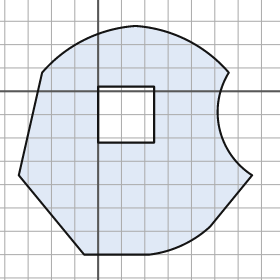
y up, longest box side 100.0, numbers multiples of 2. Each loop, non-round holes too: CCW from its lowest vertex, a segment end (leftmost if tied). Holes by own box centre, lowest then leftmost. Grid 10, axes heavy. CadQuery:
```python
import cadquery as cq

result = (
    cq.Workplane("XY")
    .moveTo(-6.0, -70.0)
    .lineTo(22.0, -70.0)
    .threePointArc((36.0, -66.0), (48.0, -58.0))
    .lineTo(66.0, -36.0)
    .threePointArc((52.0, -16.0), (56.0, 8.0))
    .threePointArc((38.0, 22.0), (16.0, 28.0))
    .threePointArc((-6.0, 22.0), (-24.0, 8.0))
    .lineTo(-34.0, -36.0)
    .close()
    .moveTo(0.0, -22.0)
    .lineTo(24.0, -22.0)
    .lineTo(24.0, 2.0)
    .lineTo(0.0, 2.0)
    .close()
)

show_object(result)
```